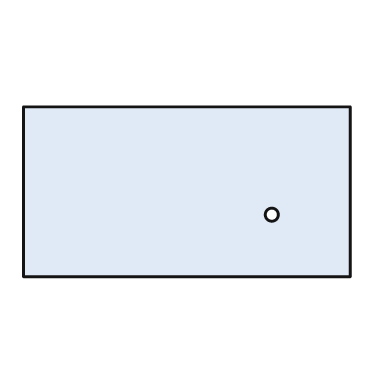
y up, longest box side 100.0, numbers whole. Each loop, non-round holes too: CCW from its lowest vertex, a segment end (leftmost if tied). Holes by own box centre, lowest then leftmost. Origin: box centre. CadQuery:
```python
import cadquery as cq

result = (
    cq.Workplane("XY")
    .moveTo(-50.0, -26.0)
    .lineTo(50.0, -26.0)
    .lineTo(50.0, 26.0)
    .lineTo(-50.0, 26.0)
    .close()
    .moveTo(26.0, -7.0)
    .circle(2.0)
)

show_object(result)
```